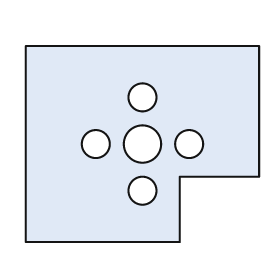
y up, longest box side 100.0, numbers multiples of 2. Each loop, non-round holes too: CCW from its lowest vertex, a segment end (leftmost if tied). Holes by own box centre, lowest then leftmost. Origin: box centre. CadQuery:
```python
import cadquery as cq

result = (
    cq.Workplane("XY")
    .moveTo(-50.0, -42.0)
    .lineTo(16.0, -42.0)
    .lineTo(16.0, -14.0)
    .lineTo(50.0, -14.0)
    .lineTo(50.0, 42.0)
    .lineTo(-50.0, 42.0)
    .close()
    .moveTo(0.0, -20.0)
    .circle(6.0)
    .moveTo(-20.0, 0.0)
    .circle(6.0)
    .moveTo(0.0, 0.0)
    .circle(8.0)
    .moveTo(20.0, 0.0)
    .circle(6.0)
    .moveTo(0.0, 20.0)
    .circle(6.0)
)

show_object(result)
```